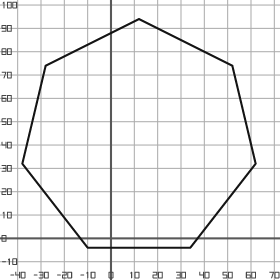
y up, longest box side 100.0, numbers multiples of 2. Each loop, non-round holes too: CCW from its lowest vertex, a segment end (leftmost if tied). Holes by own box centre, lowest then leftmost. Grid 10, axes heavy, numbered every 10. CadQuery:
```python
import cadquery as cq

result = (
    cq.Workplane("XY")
    .moveTo(-10.0, -4.0)
    .lineTo(34.0, -4.0)
    .lineTo(62.0, 32.0)
    .lineTo(52.0, 74.0)
    .lineTo(12.0, 94.0)
    .lineTo(-28.0, 74.0)
    .lineTo(-38.0, 32.0)
    .close()
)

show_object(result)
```